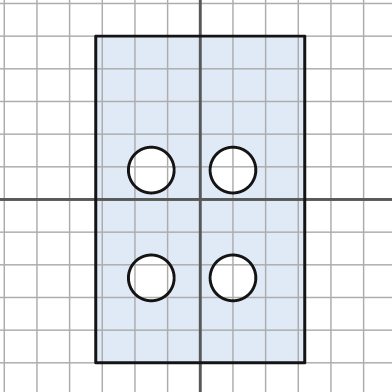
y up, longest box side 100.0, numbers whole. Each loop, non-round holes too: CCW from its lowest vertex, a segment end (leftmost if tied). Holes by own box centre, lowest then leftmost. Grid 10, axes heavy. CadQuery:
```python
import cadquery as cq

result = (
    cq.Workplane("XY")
    .moveTo(-32.0, -50.0)
    .lineTo(32.0, -50.0)
    .lineTo(32.0, 50.0)
    .lineTo(-32.0, 50.0)
    .close()
    .moveTo(-15.0, -24.0)
    .circle(7.0)
    .moveTo(10.0, -24.0)
    .circle(7.0)
    .moveTo(-15.0, 9.0)
    .circle(7.0)
    .moveTo(10.0, 9.0)
    .circle(7.0)
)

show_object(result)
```